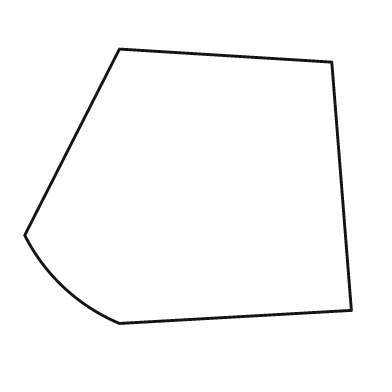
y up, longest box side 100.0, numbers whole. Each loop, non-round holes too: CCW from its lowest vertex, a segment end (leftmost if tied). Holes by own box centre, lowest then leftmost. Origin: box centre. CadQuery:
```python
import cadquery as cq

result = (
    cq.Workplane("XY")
    .moveTo(-21.0, -42.0)
    .lineTo(50.0, -38.0)
    .lineTo(44.0, 38.0)
    .lineTo(-21.0, 42.0)
    .lineTo(-50.0, -15.0)
    .threePointArc((-38.0, -31.0), (-21.0, -42.0))
    .close()
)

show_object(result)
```